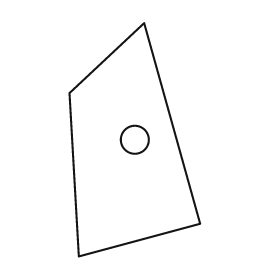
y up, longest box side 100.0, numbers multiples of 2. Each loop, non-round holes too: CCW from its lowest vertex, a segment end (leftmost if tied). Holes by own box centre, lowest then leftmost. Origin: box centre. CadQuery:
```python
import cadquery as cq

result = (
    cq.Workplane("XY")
    .moveTo(-24.0, -50.0)
    .lineTo(28.0, -36.0)
    .lineTo(4.0, 50.0)
    .lineTo(-28.0, 20.0)
    .close()
    .moveTo(0.0, 0.0)
    .circle(6.0)
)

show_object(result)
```